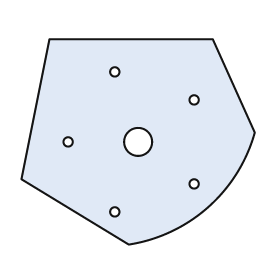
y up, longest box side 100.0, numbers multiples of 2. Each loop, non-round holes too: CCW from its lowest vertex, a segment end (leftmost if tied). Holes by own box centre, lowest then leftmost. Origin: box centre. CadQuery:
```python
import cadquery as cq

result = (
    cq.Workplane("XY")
    .moveTo(-4.0, -44.0)
    .threePointArc((30.0, -28.0), (50.0, 4.0))
    .lineTo(32.0, 44.0)
    .lineTo(-38.0, 44.0)
    .lineTo(-50.0, -16.0)
    .close()
    .moveTo(-10.0, -30.0)
    .circle(2.0)
    .moveTo(24.0, -18.0)
    .circle(2.0)
    .moveTo(-30.0, 0.0)
    .circle(2.0)
    .moveTo(0.0, 0.0)
    .circle(6.0)
    .moveTo(24.0, 18.0)
    .circle(2.0)
    .moveTo(-10.0, 30.0)
    .circle(2.0)
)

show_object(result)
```